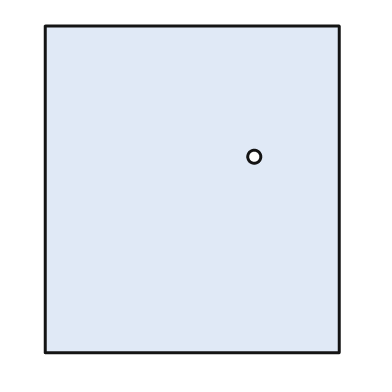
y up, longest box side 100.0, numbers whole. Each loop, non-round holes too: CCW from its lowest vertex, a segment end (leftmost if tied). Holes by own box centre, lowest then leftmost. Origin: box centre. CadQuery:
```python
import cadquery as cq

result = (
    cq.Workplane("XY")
    .moveTo(-45.0, -50.0)
    .lineTo(45.0, -50.0)
    .lineTo(45.0, 50.0)
    .lineTo(-45.0, 50.0)
    .close()
    .moveTo(19.0, 10.0)
    .circle(2.0)
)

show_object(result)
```